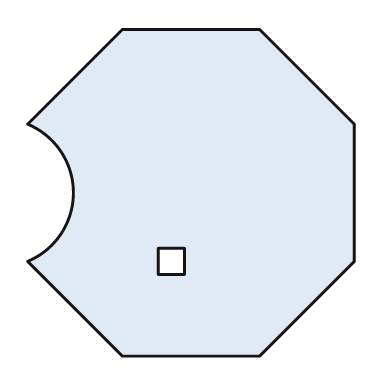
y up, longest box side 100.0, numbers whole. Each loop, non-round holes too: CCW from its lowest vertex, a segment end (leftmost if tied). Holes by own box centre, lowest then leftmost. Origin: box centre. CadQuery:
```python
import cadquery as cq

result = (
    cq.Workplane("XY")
    .moveTo(-21.0, -50.0)
    .lineTo(21.0, -50.0)
    .lineTo(50.0, -21.0)
    .lineTo(50.0, 21.0)
    .lineTo(21.0, 50.0)
    .lineTo(-21.0, 50.0)
    .lineTo(-50.0, 21.0)
    .threePointArc((-36.0, 0.0), (-50.0, -21.0))
    .close()
    .moveTo(-10.0, -25.0)
    .lineTo(-2.0, -25.0)
    .lineTo(-2.0, -17.0)
    .lineTo(-10.0, -17.0)
    .close()
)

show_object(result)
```